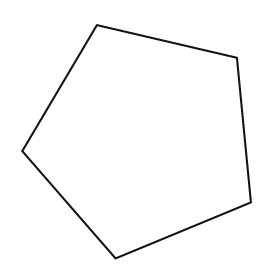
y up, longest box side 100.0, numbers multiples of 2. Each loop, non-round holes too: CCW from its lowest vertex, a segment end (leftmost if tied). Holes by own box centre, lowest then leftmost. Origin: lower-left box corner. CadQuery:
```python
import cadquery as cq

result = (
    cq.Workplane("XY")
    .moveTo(40.0, 0.0)
    .lineTo(98.0, 24.0)
    .lineTo(92.0, 86.0)
    .lineTo(32.0, 100.0)
    .lineTo(0.0, 46.0)
    .close()
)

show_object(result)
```